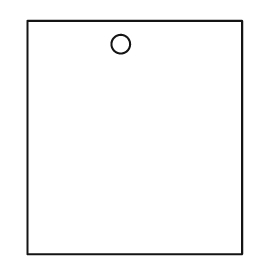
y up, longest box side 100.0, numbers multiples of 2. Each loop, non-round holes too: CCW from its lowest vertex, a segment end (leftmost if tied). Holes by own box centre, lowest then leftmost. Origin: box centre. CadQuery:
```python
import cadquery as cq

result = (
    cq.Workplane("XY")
    .moveTo(-46.0, -50.0)
    .lineTo(46.0, -50.0)
    .lineTo(46.0, 50.0)
    .lineTo(-46.0, 50.0)
    .close()
    .moveTo(-6.0, 40.0)
    .circle(4.0)
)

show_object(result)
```